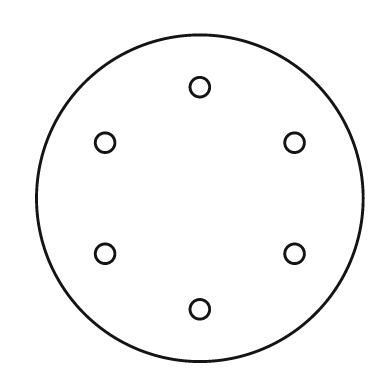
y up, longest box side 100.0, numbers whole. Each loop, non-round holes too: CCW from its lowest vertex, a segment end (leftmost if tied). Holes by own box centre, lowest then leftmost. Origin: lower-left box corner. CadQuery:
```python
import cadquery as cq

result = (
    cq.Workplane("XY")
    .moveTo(50.0, 50.0)
    .circle(50.0)
    .moveTo(50.0, 16.0)
    .circle(3.0)
    .moveTo(21.0, 33.0)
    .circle(3.0)
    .moveTo(79.0, 33.0)
    .circle(3.0)
    .moveTo(21.0, 67.0)
    .circle(3.0)
    .moveTo(79.0, 67.0)
    .circle(3.0)
    .moveTo(50.0, 84.0)
    .circle(3.0)
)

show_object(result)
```